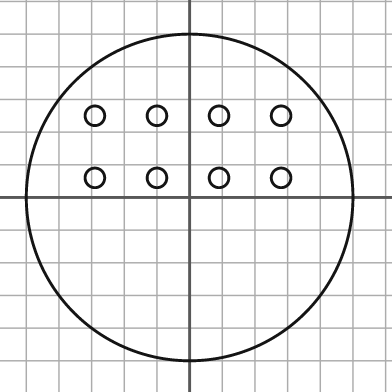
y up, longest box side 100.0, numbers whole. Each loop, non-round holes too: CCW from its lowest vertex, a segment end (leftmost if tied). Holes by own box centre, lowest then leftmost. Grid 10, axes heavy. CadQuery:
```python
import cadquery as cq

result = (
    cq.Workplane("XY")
    .moveTo(0.0, 0.0)
    .circle(50.0)
    .moveTo(-29.0, 6.0)
    .circle(3.0)
    .moveTo(-10.0, 6.0)
    .circle(3.0)
    .moveTo(9.0, 6.0)
    .circle(3.0)
    .moveTo(28.0, 6.0)
    .circle(3.0)
    .moveTo(-29.0, 25.0)
    .circle(3.0)
    .moveTo(-10.0, 25.0)
    .circle(3.0)
    .moveTo(9.0, 25.0)
    .circle(3.0)
    .moveTo(28.0, 25.0)
    .circle(3.0)
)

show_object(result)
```